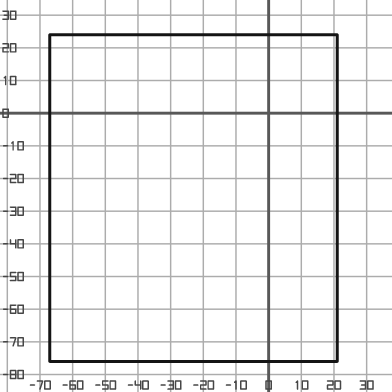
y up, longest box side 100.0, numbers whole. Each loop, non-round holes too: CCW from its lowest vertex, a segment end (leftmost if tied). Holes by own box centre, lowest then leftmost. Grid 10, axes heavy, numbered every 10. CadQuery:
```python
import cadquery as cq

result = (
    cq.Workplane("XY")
    .moveTo(-67.0, -76.0)
    .lineTo(21.0, -76.0)
    .lineTo(21.0, 24.0)
    .lineTo(-67.0, 24.0)
    .close()
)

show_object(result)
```